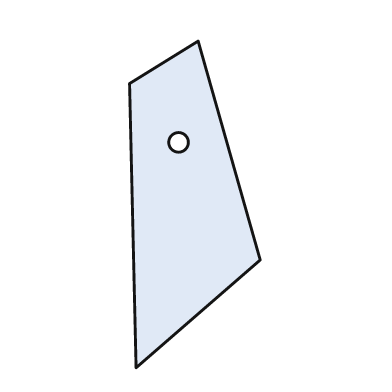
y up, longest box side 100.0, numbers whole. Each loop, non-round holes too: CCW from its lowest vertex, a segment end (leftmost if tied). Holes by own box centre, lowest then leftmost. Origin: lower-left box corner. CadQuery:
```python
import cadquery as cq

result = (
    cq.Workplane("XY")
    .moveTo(2.0, 0.0)
    .lineTo(40.0, 33.0)
    .lineTo(21.0, 100.0)
    .lineTo(0.0, 87.0)
    .close()
    .moveTo(15.0, 69.0)
    .circle(3.0)
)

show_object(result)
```